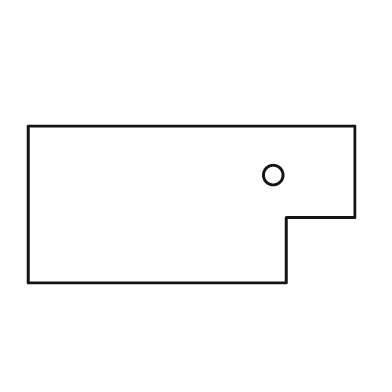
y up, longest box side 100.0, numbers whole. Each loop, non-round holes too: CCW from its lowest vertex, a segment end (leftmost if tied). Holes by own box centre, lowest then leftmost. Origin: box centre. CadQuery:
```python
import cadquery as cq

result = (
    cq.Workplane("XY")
    .moveTo(-50.0, -24.0)
    .lineTo(29.0, -24.0)
    .lineTo(29.0, -4.0)
    .lineTo(50.0, -4.0)
    .lineTo(50.0, 24.0)
    .lineTo(-50.0, 24.0)
    .close()
    .moveTo(25.0, 9.0)
    .circle(3.0)
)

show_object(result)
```